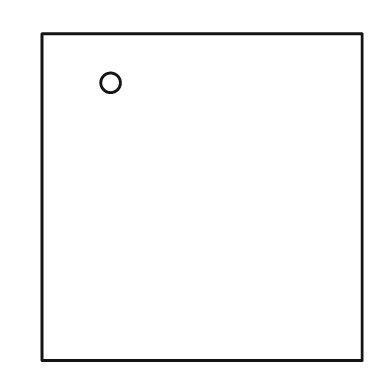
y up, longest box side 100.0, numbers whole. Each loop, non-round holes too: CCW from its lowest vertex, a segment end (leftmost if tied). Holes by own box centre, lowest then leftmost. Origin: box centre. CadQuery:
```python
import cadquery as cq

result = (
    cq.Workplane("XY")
    .moveTo(-49.0, -50.0)
    .lineTo(49.0, -50.0)
    .lineTo(49.0, 50.0)
    .lineTo(-49.0, 50.0)
    .close()
    .moveTo(-28.0, 35.0)
    .circle(3.0)
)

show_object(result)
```